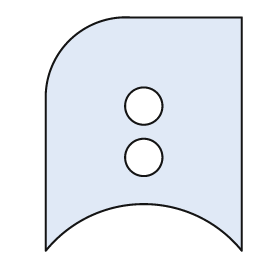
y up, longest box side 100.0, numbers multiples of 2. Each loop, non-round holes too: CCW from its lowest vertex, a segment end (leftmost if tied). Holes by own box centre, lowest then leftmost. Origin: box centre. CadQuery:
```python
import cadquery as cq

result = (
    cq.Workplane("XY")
    .moveTo(-42.0, -50.0)
    .threePointArc((0.0, -30.0), (42.0, -50.0))
    .lineTo(42.0, 50.0)
    .lineTo(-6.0, 50.0)
    .threePointArc((-32.0, 40.0), (-42.0, 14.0))
    .close()
    .moveTo(0.0, -10.0)
    .circle(8.0)
    .moveTo(0.0, 12.0)
    .circle(8.0)
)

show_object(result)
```